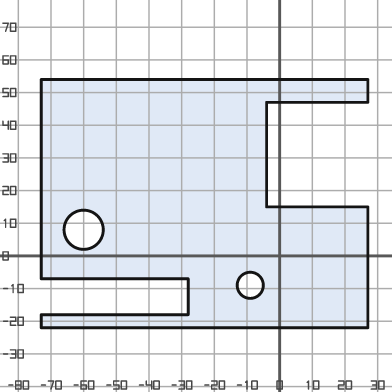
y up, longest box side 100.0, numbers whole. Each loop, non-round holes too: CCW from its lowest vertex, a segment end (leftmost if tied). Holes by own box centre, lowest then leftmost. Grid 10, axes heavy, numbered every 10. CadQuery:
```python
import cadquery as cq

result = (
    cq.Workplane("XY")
    .moveTo(-73.0, -22.0)
    .lineTo(27.0, -22.0)
    .lineTo(27.0, 15.0)
    .lineTo(-4.0, 15.0)
    .lineTo(-4.0, 47.0)
    .lineTo(27.0, 47.0)
    .lineTo(27.0, 54.0)
    .lineTo(-73.0, 54.0)
    .lineTo(-73.0, -7.0)
    .lineTo(-28.0, -7.0)
    .lineTo(-28.0, -18.0)
    .lineTo(-73.0, -18.0)
    .close()
    .moveTo(-9.0, -9.0)
    .circle(4.0)
    .moveTo(-60.0, 8.0)
    .circle(6.0)
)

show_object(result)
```